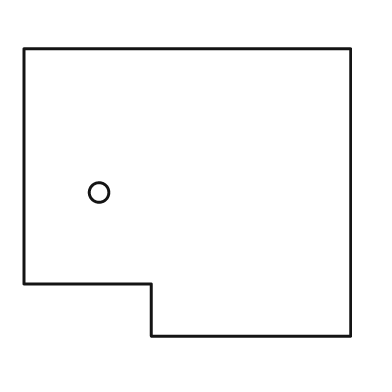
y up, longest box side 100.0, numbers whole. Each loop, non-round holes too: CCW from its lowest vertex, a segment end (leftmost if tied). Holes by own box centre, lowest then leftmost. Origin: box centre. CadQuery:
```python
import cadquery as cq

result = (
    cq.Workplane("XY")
    .moveTo(-11.0, -44.0)
    .lineTo(50.0, -44.0)
    .lineTo(50.0, 44.0)
    .lineTo(-50.0, 44.0)
    .lineTo(-50.0, -28.0)
    .lineTo(-11.0, -28.0)
    .close()
    .moveTo(-27.0, 0.0)
    .circle(3.0)
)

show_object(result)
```